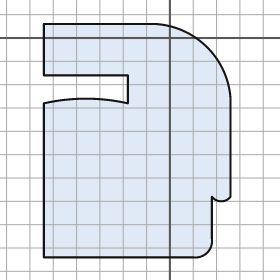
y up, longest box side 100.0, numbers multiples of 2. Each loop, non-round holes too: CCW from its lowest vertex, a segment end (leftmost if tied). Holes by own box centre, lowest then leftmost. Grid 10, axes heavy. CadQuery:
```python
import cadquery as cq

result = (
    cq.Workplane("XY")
    .moveTo(-54.0, -94.0)
    .lineTo(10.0, -94.0)
    .threePointArc((16.0, -92.0), (18.0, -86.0))
    .lineTo(18.0, -68.0)
    .threePointArc((22.0, -70.0), (26.0, -68.0))
    .lineTo(26.0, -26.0)
    .threePointArc((16.0, -4.0), (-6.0, 6.0))
    .lineTo(-54.0, 6.0)
    .lineTo(-54.0, -16.0)
    .lineTo(-18.0, -16.0)
    .lineTo(-18.0, -28.0)
    .threePointArc((-36.0, -26.0), (-54.0, -28.0))
    .close()
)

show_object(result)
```